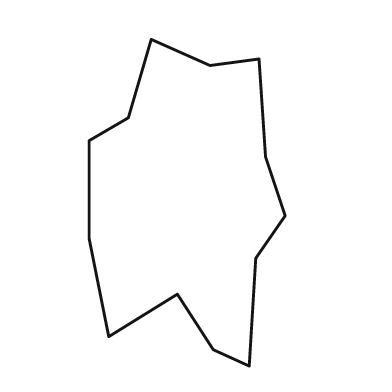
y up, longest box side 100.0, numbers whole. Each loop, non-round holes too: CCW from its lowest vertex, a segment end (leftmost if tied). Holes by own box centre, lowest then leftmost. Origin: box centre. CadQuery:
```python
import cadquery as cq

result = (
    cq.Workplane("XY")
    .moveTo(19.0, -50.0)
    .lineTo(21.0, -17.0)
    .lineTo(30.0, -4.0)
    .lineTo(24.0, 14.0)
    .lineTo(22.0, 44.0)
    .lineTo(7.0, 42.0)
    .lineTo(-11.0, 50.0)
    .lineTo(-18.0, 26.0)
    .lineTo(-30.0, 19.0)
    .lineTo(-30.0, -11.0)
    .lineTo(-24.0, -41.0)
    .lineTo(-3.0, -28.0)
    .lineTo(8.0, -45.0)
    .close()
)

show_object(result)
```